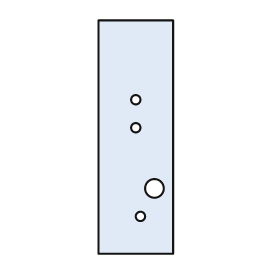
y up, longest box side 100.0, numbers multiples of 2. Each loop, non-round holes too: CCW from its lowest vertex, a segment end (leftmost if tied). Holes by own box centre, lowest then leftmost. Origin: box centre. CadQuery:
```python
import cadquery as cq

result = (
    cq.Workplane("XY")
    .moveTo(-16.0, -50.0)
    .lineTo(16.0, -50.0)
    .lineTo(16.0, 50.0)
    .lineTo(-16.0, 50.0)
    .close()
    .moveTo(2.0, -34.0)
    .circle(2.0)
    .moveTo(8.0, -22.0)
    .circle(4.0)
    .moveTo(0.0, 4.0)
    .circle(2.0)
    .moveTo(0.0, 16.0)
    .circle(2.0)
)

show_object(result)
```